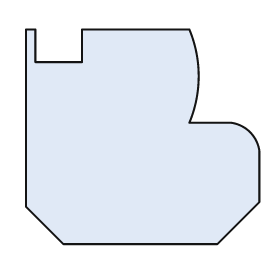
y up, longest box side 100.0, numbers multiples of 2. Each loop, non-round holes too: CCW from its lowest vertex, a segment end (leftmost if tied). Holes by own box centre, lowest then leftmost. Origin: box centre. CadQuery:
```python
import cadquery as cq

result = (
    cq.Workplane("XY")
    .moveTo(-34.0, -46.0)
    .lineTo(32.0, -46.0)
    .lineTo(50.0, -28.0)
    .lineTo(50.0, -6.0)
    .threePointArc((46.0, 2.0), (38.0, 6.0))
    .lineTo(20.0, 6.0)
    .threePointArc((24.0, 26.0), (20.0, 46.0))
    .lineTo(-26.0, 46.0)
    .lineTo(-26.0, 32.0)
    .lineTo(-46.0, 32.0)
    .lineTo(-46.0, 46.0)
    .lineTo(-50.0, 46.0)
    .lineTo(-50.0, -30.0)
    .close()
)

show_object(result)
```